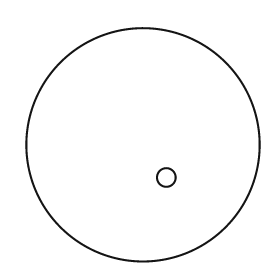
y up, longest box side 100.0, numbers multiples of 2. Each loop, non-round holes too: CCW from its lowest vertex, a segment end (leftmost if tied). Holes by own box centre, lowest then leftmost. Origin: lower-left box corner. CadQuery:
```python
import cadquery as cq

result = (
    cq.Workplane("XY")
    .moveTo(50.0, 50.0)
    .circle(50.0)
    .moveTo(60.0, 36.0)
    .circle(4.0)
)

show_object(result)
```